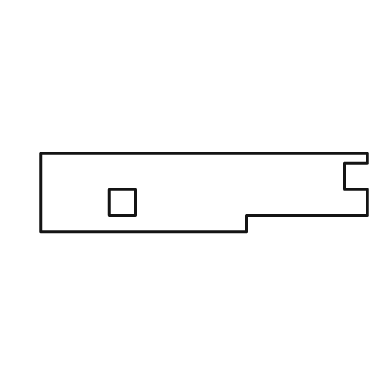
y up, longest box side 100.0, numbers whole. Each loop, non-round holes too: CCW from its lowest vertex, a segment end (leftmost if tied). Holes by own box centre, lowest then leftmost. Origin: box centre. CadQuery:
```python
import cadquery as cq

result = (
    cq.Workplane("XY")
    .moveTo(-50.0, -12.0)
    .lineTo(13.0, -12.0)
    .lineTo(13.0, -7.0)
    .lineTo(50.0, -7.0)
    .lineTo(50.0, 1.0)
    .lineTo(43.0, 1.0)
    .lineTo(43.0, 9.0)
    .lineTo(50.0, 9.0)
    .lineTo(50.0, 12.0)
    .lineTo(-50.0, 12.0)
    .close()
    .moveTo(-29.0, -7.0)
    .lineTo(-21.0, -7.0)
    .lineTo(-21.0, 1.0)
    .lineTo(-29.0, 1.0)
    .close()
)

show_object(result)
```